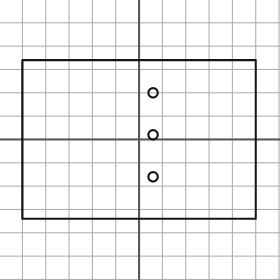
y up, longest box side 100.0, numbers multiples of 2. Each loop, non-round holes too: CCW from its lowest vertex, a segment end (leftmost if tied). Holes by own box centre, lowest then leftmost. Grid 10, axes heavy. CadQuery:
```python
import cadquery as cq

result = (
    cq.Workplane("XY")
    .moveTo(-50.0, -34.0)
    .lineTo(50.0, -34.0)
    .lineTo(50.0, 34.0)
    .lineTo(-50.0, 34.0)
    .close()
    .moveTo(6.0, -16.0)
    .circle(2.0)
    .moveTo(6.0, 2.0)
    .circle(2.0)
    .moveTo(6.0, 20.0)
    .circle(2.0)
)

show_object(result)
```